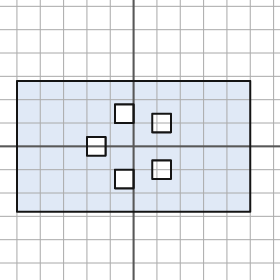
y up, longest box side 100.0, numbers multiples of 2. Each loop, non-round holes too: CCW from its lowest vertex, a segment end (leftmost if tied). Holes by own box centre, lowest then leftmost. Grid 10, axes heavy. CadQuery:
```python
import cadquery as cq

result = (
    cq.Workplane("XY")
    .moveTo(-50.0, -28.0)
    .lineTo(50.0, -28.0)
    .lineTo(50.0, 28.0)
    .lineTo(-50.0, 28.0)
    .close()
    .moveTo(-8.0, -18.0)
    .lineTo(0.0, -18.0)
    .lineTo(0.0, -10.0)
    .lineTo(-8.0, -10.0)
    .close()
    .moveTo(8.0, -14.0)
    .lineTo(16.0, -14.0)
    .lineTo(16.0, -6.0)
    .lineTo(8.0, -6.0)
    .close()
    .moveTo(-20.0, -4.0)
    .lineTo(-12.0, -4.0)
    .lineTo(-12.0, 4.0)
    .lineTo(-20.0, 4.0)
    .close()
    .moveTo(8.0, 6.0)
    .lineTo(16.0, 6.0)
    .lineTo(16.0, 14.0)
    .lineTo(8.0, 14.0)
    .close()
    .moveTo(-8.0, 10.0)
    .lineTo(0.0, 10.0)
    .lineTo(0.0, 18.0)
    .lineTo(-8.0, 18.0)
    .close()
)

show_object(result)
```